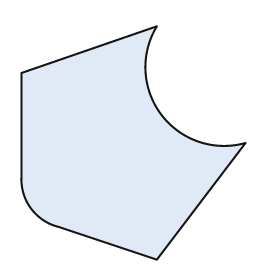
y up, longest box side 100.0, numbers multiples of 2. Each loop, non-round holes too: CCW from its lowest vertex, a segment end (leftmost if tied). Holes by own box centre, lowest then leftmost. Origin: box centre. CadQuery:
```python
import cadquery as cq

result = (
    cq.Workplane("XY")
    .moveTo(10.0, -50.0)
    .lineTo(48.0, 0.0)
    .threePointArc((12.0, 12.0), (10.0, 50.0))
    .lineTo(-48.0, 30.0)
    .lineTo(-48.0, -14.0)
    .threePointArc((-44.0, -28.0), (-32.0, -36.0))
    .close()
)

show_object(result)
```